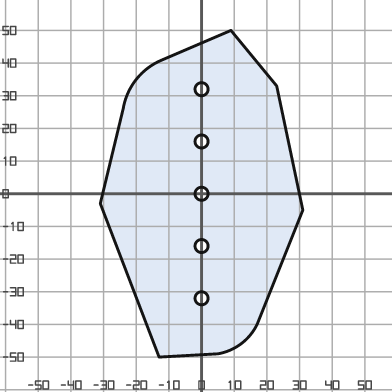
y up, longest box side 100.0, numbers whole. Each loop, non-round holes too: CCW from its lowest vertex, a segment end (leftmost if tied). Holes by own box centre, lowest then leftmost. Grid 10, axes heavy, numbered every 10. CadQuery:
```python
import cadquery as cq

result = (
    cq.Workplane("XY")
    .moveTo(-13.0, -50.0)
    .lineTo(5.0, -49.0)
    .threePointArc((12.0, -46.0), (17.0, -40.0))
    .lineTo(31.0, -5.0)
    .lineTo(23.0, 33.0)
    .lineTo(9.0, 50.0)
    .lineTo(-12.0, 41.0)
    .threePointArc((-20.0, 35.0), (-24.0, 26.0))
    .lineTo(-31.0, -3.0)
    .close()
    .moveTo(0.0, -32.0)
    .circle(2.0)
    .moveTo(0.0, -16.0)
    .circle(2.0)
    .moveTo(0.0, 0.0)
    .circle(2.0)
    .moveTo(0.0, 16.0)
    .circle(2.0)
    .moveTo(0.0, 32.0)
    .circle(2.0)
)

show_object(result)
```